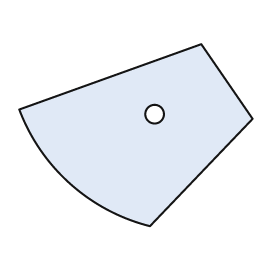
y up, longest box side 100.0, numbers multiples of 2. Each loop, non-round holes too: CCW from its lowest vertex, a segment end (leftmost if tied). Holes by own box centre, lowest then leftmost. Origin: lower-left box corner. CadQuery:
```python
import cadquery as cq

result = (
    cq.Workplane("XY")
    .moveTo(56.0, 0.0)
    .lineTo(100.0, 46.0)
    .lineTo(78.0, 78.0)
    .lineTo(0.0, 50.0)
    .threePointArc((22.0, 18.0), (56.0, 0.0))
    .close()
    .moveTo(58.0, 48.0)
    .circle(4.0)
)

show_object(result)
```